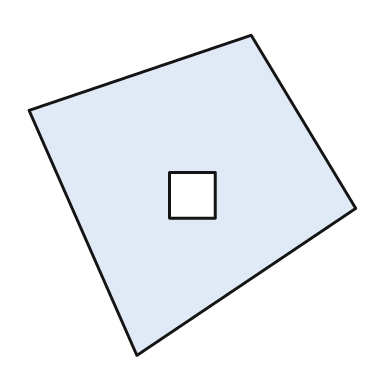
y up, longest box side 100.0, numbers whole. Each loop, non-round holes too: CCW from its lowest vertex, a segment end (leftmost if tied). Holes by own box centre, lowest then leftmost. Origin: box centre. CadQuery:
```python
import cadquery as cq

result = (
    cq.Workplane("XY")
    .moveTo(-17.0, -49.0)
    .lineTo(50.0, -4.0)
    .lineTo(18.0, 49.0)
    .lineTo(-50.0, 26.0)
    .close()
    .moveTo(-7.0, -7.0)
    .lineTo(7.0, -7.0)
    .lineTo(7.0, 7.0)
    .lineTo(-7.0, 7.0)
    .close()
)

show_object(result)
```